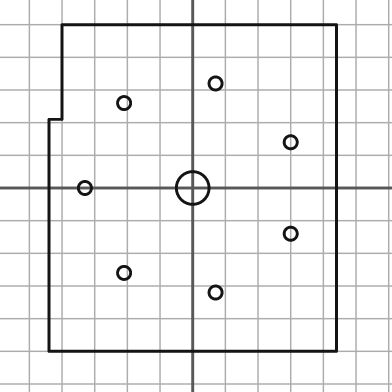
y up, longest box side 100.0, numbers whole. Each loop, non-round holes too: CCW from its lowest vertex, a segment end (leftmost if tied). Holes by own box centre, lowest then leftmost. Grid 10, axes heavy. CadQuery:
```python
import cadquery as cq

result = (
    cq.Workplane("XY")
    .moveTo(-44.0, -50.0)
    .lineTo(44.0, -50.0)
    .lineTo(44.0, 50.0)
    .lineTo(-40.0, 50.0)
    .lineTo(-40.0, 21.0)
    .lineTo(-44.0, 21.0)
    .close()
    .moveTo(7.0, -32.0)
    .circle(2.0)
    .moveTo(-21.0, -26.0)
    .circle(2.0)
    .moveTo(30.0, -14.0)
    .circle(2.0)
    .moveTo(-33.0, 0.0)
    .circle(2.0)
    .moveTo(0.0, 0.0)
    .circle(5.0)
    .moveTo(30.0, 14.0)
    .circle(2.0)
    .moveTo(-21.0, 26.0)
    .circle(2.0)
    .moveTo(7.0, 32.0)
    .circle(2.0)
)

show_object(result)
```